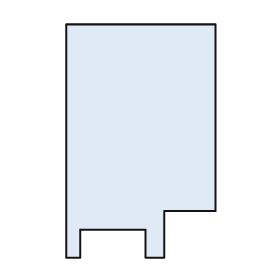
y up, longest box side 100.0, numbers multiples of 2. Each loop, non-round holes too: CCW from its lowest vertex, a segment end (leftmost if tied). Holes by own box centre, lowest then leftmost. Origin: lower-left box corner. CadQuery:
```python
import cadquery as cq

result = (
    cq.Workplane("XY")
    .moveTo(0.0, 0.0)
    .lineTo(6.0, 0.0)
    .lineTo(6.0, 12.0)
    .lineTo(34.0, 12.0)
    .lineTo(34.0, 0.0)
    .lineTo(42.0, 0.0)
    .lineTo(42.0, 20.0)
    .lineTo(64.0, 20.0)
    .lineTo(64.0, 100.0)
    .lineTo(0.0, 100.0)
    .close()
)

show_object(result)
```